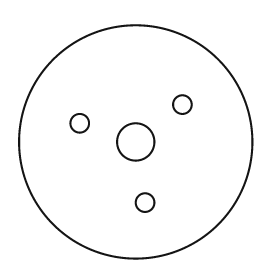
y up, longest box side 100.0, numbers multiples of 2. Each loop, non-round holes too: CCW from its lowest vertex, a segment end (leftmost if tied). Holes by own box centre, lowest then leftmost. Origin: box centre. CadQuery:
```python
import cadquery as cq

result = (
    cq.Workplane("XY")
    .moveTo(0.0, 0.0)
    .circle(50.0)
    .moveTo(4.0, -26.0)
    .circle(4.0)
    .moveTo(0.0, 0.0)
    .circle(8.0)
    .moveTo(-24.0, 8.0)
    .circle(4.0)
    .moveTo(20.0, 16.0)
    .circle(4.0)
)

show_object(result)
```